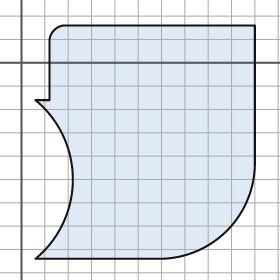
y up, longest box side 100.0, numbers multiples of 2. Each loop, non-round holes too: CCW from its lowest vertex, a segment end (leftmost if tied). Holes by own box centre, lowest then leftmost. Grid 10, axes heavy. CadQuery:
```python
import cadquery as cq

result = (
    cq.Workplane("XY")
    .moveTo(6.0, -84.0)
    .lineTo(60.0, -84.0)
    .threePointArc((88.0, -72.0), (100.0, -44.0))
    .lineTo(100.0, 16.0)
    .lineTo(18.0, 16.0)
    .threePointArc((14.0, 14.0), (12.0, 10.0))
    .lineTo(12.0, -16.0)
    .lineTo(6.0, -16.0)
    .threePointArc((22.0, -50.0), (6.0, -84.0))
    .close()
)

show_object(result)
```